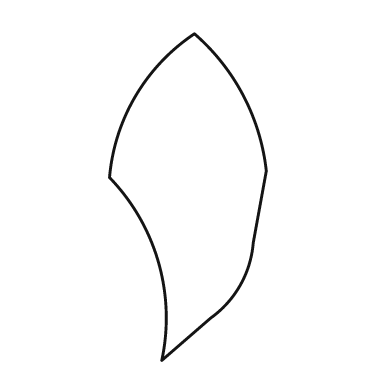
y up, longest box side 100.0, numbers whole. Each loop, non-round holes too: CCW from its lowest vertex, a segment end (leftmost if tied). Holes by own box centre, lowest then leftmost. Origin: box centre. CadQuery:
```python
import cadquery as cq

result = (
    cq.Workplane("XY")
    .moveTo(-8.0, -50.0)
    .lineTo(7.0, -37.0)
    .threePointArc((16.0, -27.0), (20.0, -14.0))
    .lineTo(24.0, 8.0)
    .threePointArc((17.0, 31.0), (2.0, 50.0))
    .threePointArc((-16.0, 31.0), (-24.0, 6.0))
    .threePointArc((-9.0, -20.0), (-8.0, -50.0))
    .close()
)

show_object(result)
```